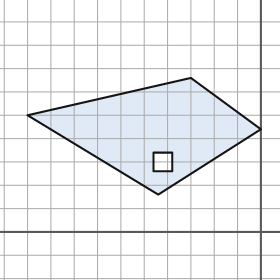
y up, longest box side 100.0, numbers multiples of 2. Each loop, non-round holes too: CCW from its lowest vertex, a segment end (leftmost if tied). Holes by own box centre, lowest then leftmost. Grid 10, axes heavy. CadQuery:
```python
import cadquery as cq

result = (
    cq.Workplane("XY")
    .moveTo(-44.0, 16.0)
    .lineTo(0.0, 44.0)
    .lineTo(-30.0, 66.0)
    .lineTo(-100.0, 50.0)
    .close()
    .moveTo(-46.0, 26.0)
    .lineTo(-38.0, 26.0)
    .lineTo(-38.0, 34.0)
    .lineTo(-46.0, 34.0)
    .close()
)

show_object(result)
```